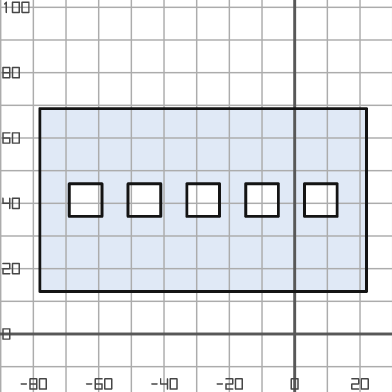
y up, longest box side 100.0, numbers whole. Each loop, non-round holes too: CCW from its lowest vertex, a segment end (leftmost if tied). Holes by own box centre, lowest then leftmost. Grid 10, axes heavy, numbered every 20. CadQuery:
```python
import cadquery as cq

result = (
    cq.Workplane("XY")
    .moveTo(-78.0, 13.0)
    .lineTo(22.0, 13.0)
    .lineTo(22.0, 69.0)
    .lineTo(-78.0, 69.0)
    .close()
    .moveTo(-69.0, 36.0)
    .lineTo(-59.0, 36.0)
    .lineTo(-59.0, 46.0)
    .lineTo(-69.0, 46.0)
    .close()
    .moveTo(-51.0, 36.0)
    .lineTo(-41.0, 36.0)
    .lineTo(-41.0, 46.0)
    .lineTo(-51.0, 46.0)
    .close()
    .moveTo(-33.0, 36.0)
    .lineTo(-23.0, 36.0)
    .lineTo(-23.0, 46.0)
    .lineTo(-33.0, 46.0)
    .close()
    .moveTo(-15.0, 36.0)
    .lineTo(-5.0, 36.0)
    .lineTo(-5.0, 46.0)
    .lineTo(-15.0, 46.0)
    .close()
    .moveTo(3.0, 36.0)
    .lineTo(13.0, 36.0)
    .lineTo(13.0, 46.0)
    .lineTo(3.0, 46.0)
    .close()
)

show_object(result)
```